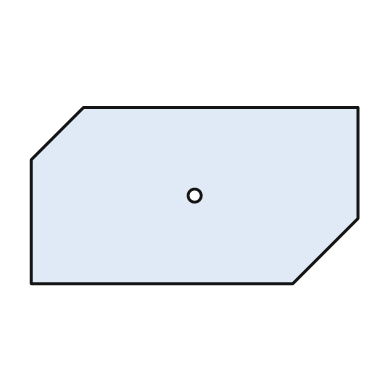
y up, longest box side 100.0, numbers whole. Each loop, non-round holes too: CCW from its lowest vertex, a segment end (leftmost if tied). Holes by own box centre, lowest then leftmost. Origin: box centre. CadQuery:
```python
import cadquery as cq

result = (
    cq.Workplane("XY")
    .moveTo(-50.0, -27.0)
    .lineTo(30.0, -27.0)
    .lineTo(50.0, -7.0)
    .lineTo(50.0, 27.0)
    .lineTo(-34.0, 27.0)
    .lineTo(-50.0, 11.0)
    .close()
    .moveTo(0.0, 0.0)
    .circle(2.0)
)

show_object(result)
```